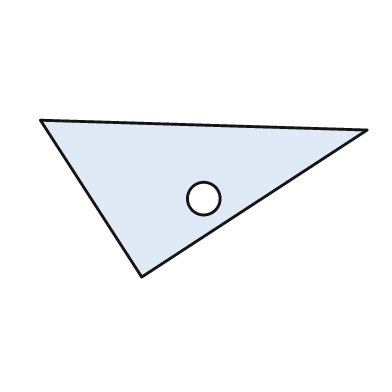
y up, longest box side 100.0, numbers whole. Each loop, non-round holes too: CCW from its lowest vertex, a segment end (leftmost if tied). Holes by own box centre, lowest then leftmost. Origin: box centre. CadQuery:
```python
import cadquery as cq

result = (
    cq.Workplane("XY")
    .moveTo(-19.0, -24.0)
    .lineTo(50.0, 21.0)
    .lineTo(-50.0, 24.0)
    .close()
    .moveTo(0.0, 0.0)
    .circle(5.0)
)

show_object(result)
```